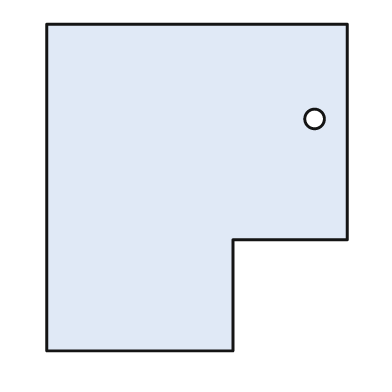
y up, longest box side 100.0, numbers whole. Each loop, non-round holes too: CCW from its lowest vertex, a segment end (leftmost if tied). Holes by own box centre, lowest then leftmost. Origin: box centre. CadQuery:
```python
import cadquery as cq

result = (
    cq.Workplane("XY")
    .moveTo(-46.0, -50.0)
    .lineTo(11.0, -50.0)
    .lineTo(11.0, -16.0)
    .lineTo(46.0, -16.0)
    .lineTo(46.0, 50.0)
    .lineTo(-46.0, 50.0)
    .close()
    .moveTo(36.0, 21.0)
    .circle(3.0)
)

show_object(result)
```